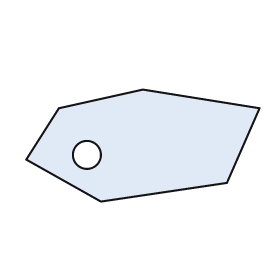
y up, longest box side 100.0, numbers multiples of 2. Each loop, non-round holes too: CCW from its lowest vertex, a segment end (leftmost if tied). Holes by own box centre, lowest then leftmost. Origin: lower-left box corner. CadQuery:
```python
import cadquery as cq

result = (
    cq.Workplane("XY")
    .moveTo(32.0, 0.0)
    .lineTo(86.0, 8.0)
    .lineTo(100.0, 40.0)
    .lineTo(50.0, 48.0)
    .lineTo(14.0, 40.0)
    .lineTo(0.0, 18.0)
    .close()
    .moveTo(26.0, 20.0)
    .circle(6.0)
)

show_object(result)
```